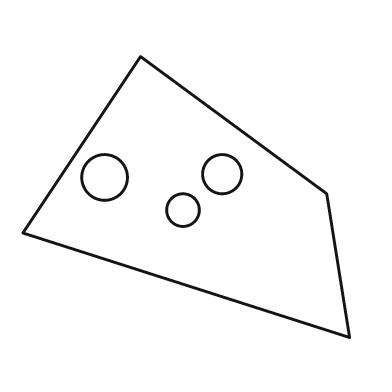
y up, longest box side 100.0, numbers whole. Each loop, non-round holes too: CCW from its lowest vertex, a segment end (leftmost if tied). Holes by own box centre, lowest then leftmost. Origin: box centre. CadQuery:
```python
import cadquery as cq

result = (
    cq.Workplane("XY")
    .moveTo(50.0, -43.0)
    .lineTo(43.0, 1.0)
    .lineTo(-14.0, 43.0)
    .lineTo(-50.0, -11.0)
    .close()
    .moveTo(-1.0, -4.0)
    .circle(5.0)
    .moveTo(-25.0, 6.0)
    .circle(7.0)
    .moveTo(11.0, 7.0)
    .circle(6.0)
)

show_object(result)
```